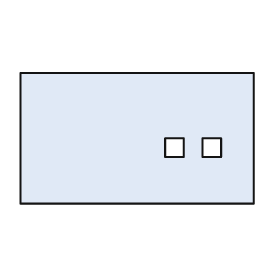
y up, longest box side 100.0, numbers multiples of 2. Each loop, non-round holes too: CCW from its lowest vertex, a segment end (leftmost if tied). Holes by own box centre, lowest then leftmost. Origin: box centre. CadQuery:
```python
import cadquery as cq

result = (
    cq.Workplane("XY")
    .moveTo(-50.0, -28.0)
    .lineTo(50.0, -28.0)
    .lineTo(50.0, 28.0)
    .lineTo(-50.0, 28.0)
    .close()
    .moveTo(12.0, -8.0)
    .lineTo(20.0, -8.0)
    .lineTo(20.0, 0.0)
    .lineTo(12.0, 0.0)
    .close()
    .moveTo(28.0, -8.0)
    .lineTo(36.0, -8.0)
    .lineTo(36.0, 0.0)
    .lineTo(28.0, 0.0)
    .close()
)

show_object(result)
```